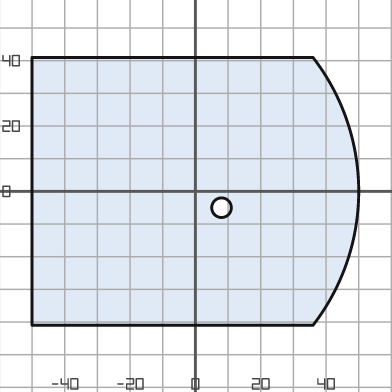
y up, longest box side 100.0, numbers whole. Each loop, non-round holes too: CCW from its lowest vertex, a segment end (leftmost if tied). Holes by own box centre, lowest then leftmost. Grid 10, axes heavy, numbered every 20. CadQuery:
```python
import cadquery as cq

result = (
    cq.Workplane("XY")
    .moveTo(-50.0, -41.0)
    .lineTo(36.0, -41.0)
    .threePointArc((50.0, 0.0), (36.0, 41.0))
    .lineTo(-50.0, 41.0)
    .close()
    .moveTo(8.0, -5.0)
    .circle(3.0)
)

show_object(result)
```